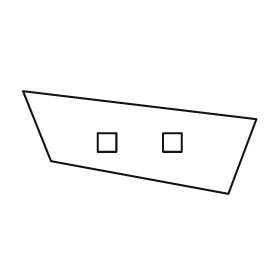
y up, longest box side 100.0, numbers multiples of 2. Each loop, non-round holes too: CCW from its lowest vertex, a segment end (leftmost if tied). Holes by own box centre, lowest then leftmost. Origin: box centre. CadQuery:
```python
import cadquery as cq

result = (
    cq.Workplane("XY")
    .moveTo(38.0, -22.0)
    .lineTo(50.0, 10.0)
    .lineTo(-50.0, 22.0)
    .lineTo(-38.0, -8.0)
    .close()
    .moveTo(-18.0, -4.0)
    .lineTo(-10.0, -4.0)
    .lineTo(-10.0, 4.0)
    .lineTo(-18.0, 4.0)
    .close()
    .moveTo(10.0, -4.0)
    .lineTo(18.0, -4.0)
    .lineTo(18.0, 4.0)
    .lineTo(10.0, 4.0)
    .close()
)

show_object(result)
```